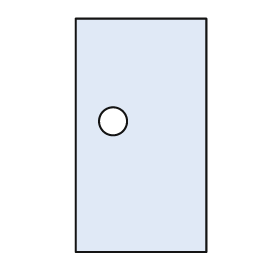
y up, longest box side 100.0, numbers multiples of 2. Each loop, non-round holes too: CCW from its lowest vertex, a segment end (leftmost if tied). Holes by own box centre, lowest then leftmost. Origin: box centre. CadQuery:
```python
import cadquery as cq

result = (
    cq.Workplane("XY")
    .moveTo(-28.0, -50.0)
    .lineTo(28.0, -50.0)
    .lineTo(28.0, 50.0)
    .lineTo(-28.0, 50.0)
    .close()
    .moveTo(-12.0, 6.0)
    .circle(6.0)
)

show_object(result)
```